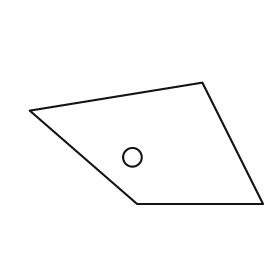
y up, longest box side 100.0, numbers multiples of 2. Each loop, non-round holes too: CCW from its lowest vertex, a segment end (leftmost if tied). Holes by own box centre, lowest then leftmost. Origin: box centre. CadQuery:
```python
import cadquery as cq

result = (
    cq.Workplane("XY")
    .moveTo(-4.0, -26.0)
    .lineTo(50.0, -26.0)
    .lineTo(24.0, 26.0)
    .lineTo(-50.0, 14.0)
    .close()
    .moveTo(-6.0, -6.0)
    .circle(4.0)
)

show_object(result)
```